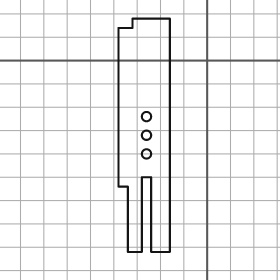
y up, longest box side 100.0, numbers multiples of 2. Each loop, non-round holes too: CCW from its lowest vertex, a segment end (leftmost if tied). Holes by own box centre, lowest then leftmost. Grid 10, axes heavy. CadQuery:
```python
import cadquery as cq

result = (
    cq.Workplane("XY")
    .moveTo(-34.0, -82.0)
    .lineTo(-28.0, -82.0)
    .lineTo(-28.0, -50.0)
    .lineTo(-24.0, -50.0)
    .lineTo(-24.0, -82.0)
    .lineTo(-16.0, -82.0)
    .lineTo(-16.0, 18.0)
    .lineTo(-32.0, 18.0)
    .lineTo(-32.0, 14.0)
    .lineTo(-38.0, 14.0)
    .lineTo(-38.0, -54.0)
    .lineTo(-34.0, -54.0)
    .close()
    .moveTo(-26.0, -40.0)
    .circle(2.0)
    .moveTo(-26.0, -32.0)
    .circle(2.0)
    .moveTo(-26.0, -24.0)
    .circle(2.0)
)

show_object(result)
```